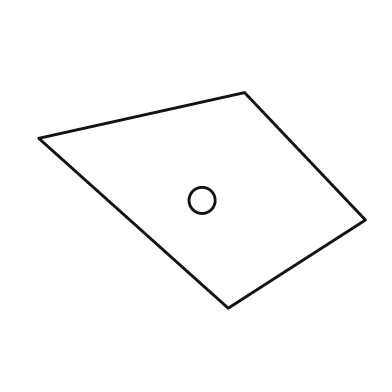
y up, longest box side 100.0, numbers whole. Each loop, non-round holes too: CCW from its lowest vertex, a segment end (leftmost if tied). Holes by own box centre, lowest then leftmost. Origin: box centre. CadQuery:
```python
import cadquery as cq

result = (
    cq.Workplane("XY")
    .moveTo(8.0, -33.0)
    .lineTo(50.0, -6.0)
    .lineTo(13.0, 33.0)
    .lineTo(-50.0, 19.0)
    .close()
    .moveTo(0.0, 0.0)
    .circle(4.0)
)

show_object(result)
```